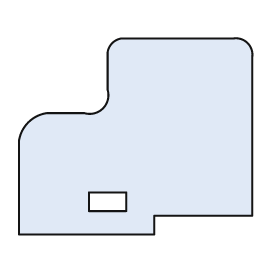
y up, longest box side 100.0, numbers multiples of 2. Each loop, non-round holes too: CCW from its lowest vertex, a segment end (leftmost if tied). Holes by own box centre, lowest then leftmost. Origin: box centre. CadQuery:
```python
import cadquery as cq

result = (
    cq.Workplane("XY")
    .moveTo(-50.0, -42.0)
    .lineTo(8.0, -42.0)
    .lineTo(8.0, -34.0)
    .lineTo(50.0, -34.0)
    .lineTo(50.0, 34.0)
    .threePointArc((48.0, 40.0), (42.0, 42.0))
    .lineTo(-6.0, 42.0)
    .threePointArc((-10.0, 40.0), (-12.0, 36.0))
    .lineTo(-12.0, 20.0)
    .threePointArc((-14.0, 12.0), (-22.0, 10.0))
    .lineTo(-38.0, 10.0)
    .threePointArc((-46.0, 6.0), (-50.0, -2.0))
    .close()
    .moveTo(-20.0, -32.0)
    .lineTo(-4.0, -32.0)
    .lineTo(-4.0, -24.0)
    .lineTo(-20.0, -24.0)
    .close()
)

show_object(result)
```